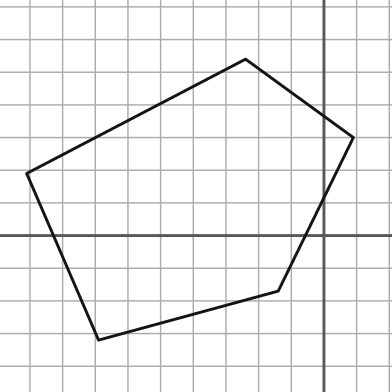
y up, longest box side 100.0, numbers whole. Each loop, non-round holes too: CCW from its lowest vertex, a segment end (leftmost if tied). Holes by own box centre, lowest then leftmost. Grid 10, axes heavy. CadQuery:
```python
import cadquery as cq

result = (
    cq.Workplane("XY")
    .moveTo(-69.0, -32.0)
    .lineTo(-14.0, -17.0)
    .lineTo(9.0, 30.0)
    .lineTo(-24.0, 54.0)
    .lineTo(-91.0, 19.0)
    .close()
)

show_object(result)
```